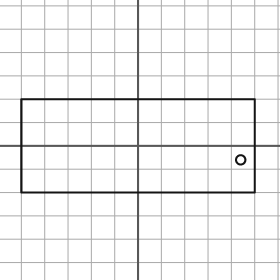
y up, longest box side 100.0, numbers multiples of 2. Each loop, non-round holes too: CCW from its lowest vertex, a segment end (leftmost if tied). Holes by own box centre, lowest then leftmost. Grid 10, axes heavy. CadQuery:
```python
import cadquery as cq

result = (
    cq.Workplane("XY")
    .moveTo(-50.0, -20.0)
    .lineTo(50.0, -20.0)
    .lineTo(50.0, 20.0)
    .lineTo(-50.0, 20.0)
    .close()
    .moveTo(44.0, -6.0)
    .circle(2.0)
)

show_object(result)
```